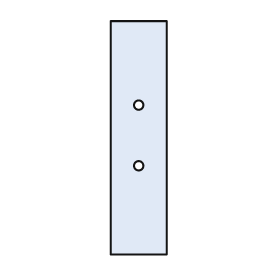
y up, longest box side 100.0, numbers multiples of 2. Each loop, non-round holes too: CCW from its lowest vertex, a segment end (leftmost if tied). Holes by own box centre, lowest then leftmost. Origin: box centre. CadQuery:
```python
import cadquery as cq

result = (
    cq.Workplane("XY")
    .moveTo(-12.0, -50.0)
    .lineTo(12.0, -50.0)
    .lineTo(12.0, 50.0)
    .lineTo(-12.0, 50.0)
    .close()
    .moveTo(0.0, -12.0)
    .circle(2.0)
    .moveTo(0.0, 14.0)
    .circle(2.0)
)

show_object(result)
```